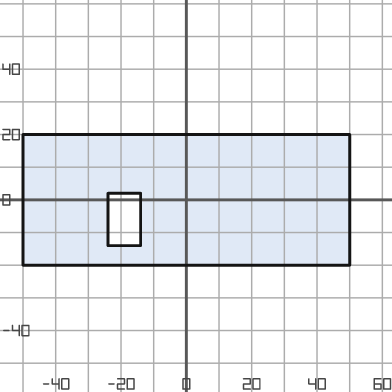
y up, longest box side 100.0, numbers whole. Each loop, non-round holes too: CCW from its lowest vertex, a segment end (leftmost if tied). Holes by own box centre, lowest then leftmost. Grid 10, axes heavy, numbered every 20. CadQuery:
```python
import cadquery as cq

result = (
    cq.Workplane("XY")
    .moveTo(-50.0, -20.0)
    .lineTo(50.0, -20.0)
    .lineTo(50.0, 20.0)
    .lineTo(-50.0, 20.0)
    .close()
    .moveTo(-24.0, -14.0)
    .lineTo(-14.0, -14.0)
    .lineTo(-14.0, 2.0)
    .lineTo(-24.0, 2.0)
    .close()
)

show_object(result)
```